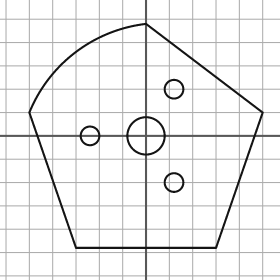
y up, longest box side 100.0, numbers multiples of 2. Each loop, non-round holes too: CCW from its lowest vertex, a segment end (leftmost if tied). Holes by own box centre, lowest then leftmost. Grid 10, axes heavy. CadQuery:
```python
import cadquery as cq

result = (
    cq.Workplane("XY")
    .moveTo(-30.0, -48.0)
    .lineTo(30.0, -48.0)
    .lineTo(50.0, 10.0)
    .lineTo(0.0, 48.0)
    .threePointArc((-30.0, 36.0), (-50.0, 10.0))
    .close()
    .moveTo(12.0, -20.0)
    .circle(4.0)
    .moveTo(-24.0, 0.0)
    .circle(4.0)
    .moveTo(0.0, 0.0)
    .circle(8.0)
    .moveTo(12.0, 20.0)
    .circle(4.0)
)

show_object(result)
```